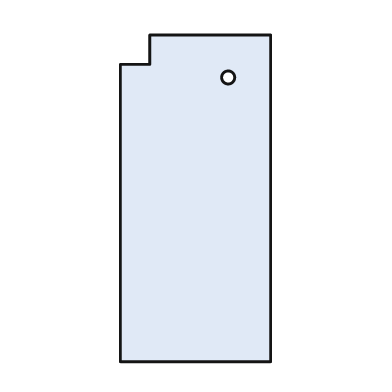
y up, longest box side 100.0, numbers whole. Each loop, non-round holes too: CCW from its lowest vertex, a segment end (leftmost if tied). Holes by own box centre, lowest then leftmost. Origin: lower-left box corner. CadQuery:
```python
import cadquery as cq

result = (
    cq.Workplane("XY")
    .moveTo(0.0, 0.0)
    .lineTo(46.0, 0.0)
    .lineTo(46.0, 100.0)
    .lineTo(9.0, 100.0)
    .lineTo(9.0, 91.0)
    .lineTo(0.0, 91.0)
    .close()
    .moveTo(33.0, 87.0)
    .circle(2.0)
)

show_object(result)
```